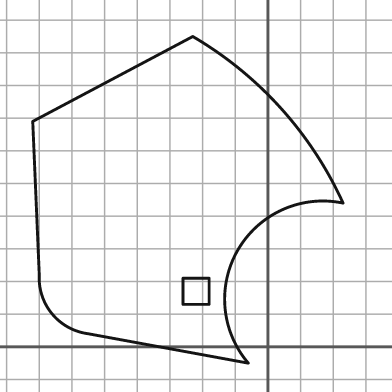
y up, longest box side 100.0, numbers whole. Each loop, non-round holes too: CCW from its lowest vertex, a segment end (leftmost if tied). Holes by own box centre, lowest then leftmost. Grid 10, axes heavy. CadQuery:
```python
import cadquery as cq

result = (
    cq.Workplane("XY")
    .moveTo(-6.0, -5.0)
    .threePointArc((-9.0, 30.0), (23.0, 44.0))
    .threePointArc((4.0, 73.0), (-23.0, 95.0))
    .lineTo(-72.0, 69.0)
    .lineTo(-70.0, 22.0)
    .threePointArc((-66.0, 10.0), (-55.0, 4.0))
    .close()
    .moveTo(-26.0, 13.0)
    .lineTo(-18.0, 13.0)
    .lineTo(-18.0, 21.0)
    .lineTo(-26.0, 21.0)
    .close()
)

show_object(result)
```